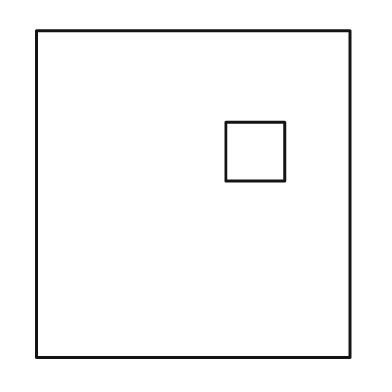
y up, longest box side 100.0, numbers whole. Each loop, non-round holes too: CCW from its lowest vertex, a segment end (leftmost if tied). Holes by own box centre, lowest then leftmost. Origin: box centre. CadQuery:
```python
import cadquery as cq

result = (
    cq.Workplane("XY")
    .moveTo(-48.0, -50.0)
    .lineTo(48.0, -50.0)
    .lineTo(48.0, 50.0)
    .lineTo(-48.0, 50.0)
    .close()
    .moveTo(10.0, 4.0)
    .lineTo(28.0, 4.0)
    .lineTo(28.0, 22.0)
    .lineTo(10.0, 22.0)
    .close()
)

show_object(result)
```